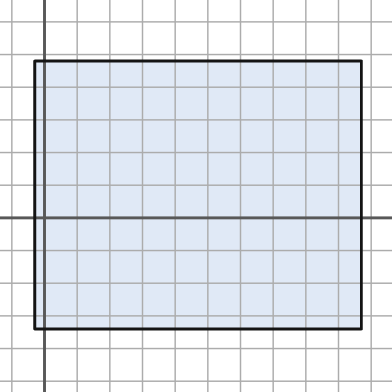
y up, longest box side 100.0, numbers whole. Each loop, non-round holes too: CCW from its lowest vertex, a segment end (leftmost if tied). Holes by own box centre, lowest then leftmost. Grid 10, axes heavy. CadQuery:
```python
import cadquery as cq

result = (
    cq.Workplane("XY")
    .moveTo(-3.0, -34.0)
    .lineTo(97.0, -34.0)
    .lineTo(97.0, 48.0)
    .lineTo(-3.0, 48.0)
    .close()
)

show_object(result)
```